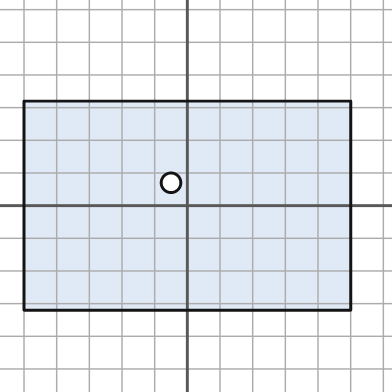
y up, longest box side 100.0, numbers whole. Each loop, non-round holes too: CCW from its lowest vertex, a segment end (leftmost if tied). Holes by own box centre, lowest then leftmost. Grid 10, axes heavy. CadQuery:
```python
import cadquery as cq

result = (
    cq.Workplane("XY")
    .moveTo(-50.0, -32.0)
    .lineTo(50.0, -32.0)
    .lineTo(50.0, 32.0)
    .lineTo(-50.0, 32.0)
    .close()
    .moveTo(-5.0, 7.0)
    .circle(3.0)
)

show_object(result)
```